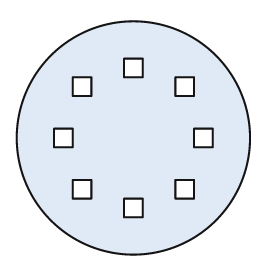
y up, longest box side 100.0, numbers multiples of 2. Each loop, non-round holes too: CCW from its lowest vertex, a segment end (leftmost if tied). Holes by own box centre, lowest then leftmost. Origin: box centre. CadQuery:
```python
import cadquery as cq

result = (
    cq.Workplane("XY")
    .moveTo(0.0, 0.0)
    .circle(50.0)
    .moveTo(-4.0, -34.0)
    .lineTo(4.0, -34.0)
    .lineTo(4.0, -26.0)
    .lineTo(-4.0, -26.0)
    .close()
    .moveTo(-26.0, -26.0)
    .lineTo(-18.0, -26.0)
    .lineTo(-18.0, -18.0)
    .lineTo(-26.0, -18.0)
    .close()
    .moveTo(18.0, -26.0)
    .lineTo(26.0, -26.0)
    .lineTo(26.0, -18.0)
    .lineTo(18.0, -18.0)
    .close()
    .moveTo(-34.0, -4.0)
    .lineTo(-26.0, -4.0)
    .lineTo(-26.0, 4.0)
    .lineTo(-34.0, 4.0)
    .close()
    .moveTo(26.0, -4.0)
    .lineTo(34.0, -4.0)
    .lineTo(34.0, 4.0)
    .lineTo(26.0, 4.0)
    .close()
    .moveTo(-26.0, 18.0)
    .lineTo(-18.0, 18.0)
    .lineTo(-18.0, 26.0)
    .lineTo(-26.0, 26.0)
    .close()
    .moveTo(18.0, 18.0)
    .lineTo(26.0, 18.0)
    .lineTo(26.0, 26.0)
    .lineTo(18.0, 26.0)
    .close()
    .moveTo(-4.0, 26.0)
    .lineTo(4.0, 26.0)
    .lineTo(4.0, 34.0)
    .lineTo(-4.0, 34.0)
    .close()
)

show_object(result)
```